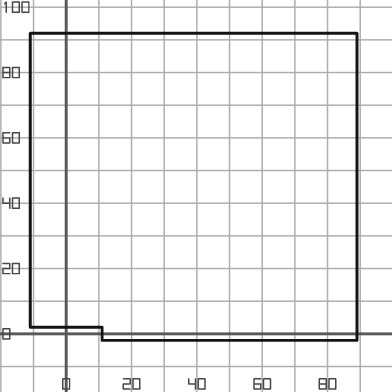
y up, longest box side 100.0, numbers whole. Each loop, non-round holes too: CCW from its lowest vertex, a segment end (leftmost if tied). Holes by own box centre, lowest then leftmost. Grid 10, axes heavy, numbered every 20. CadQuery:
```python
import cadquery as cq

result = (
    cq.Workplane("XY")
    .moveTo(11.0, -2.0)
    .lineTo(89.0, -2.0)
    .lineTo(89.0, 92.0)
    .lineTo(-11.0, 92.0)
    .lineTo(-11.0, 2.0)
    .lineTo(11.0, 2.0)
    .close()
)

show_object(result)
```